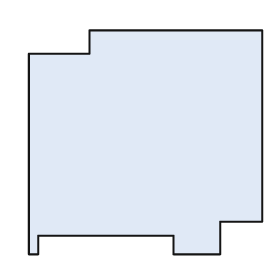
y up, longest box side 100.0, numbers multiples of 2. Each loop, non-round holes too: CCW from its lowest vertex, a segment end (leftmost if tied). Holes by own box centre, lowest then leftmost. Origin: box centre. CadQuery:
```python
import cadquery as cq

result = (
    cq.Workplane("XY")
    .moveTo(-50.0, -48.0)
    .lineTo(-46.0, -48.0)
    .lineTo(-46.0, -40.0)
    .lineTo(12.0, -40.0)
    .lineTo(12.0, -48.0)
    .lineTo(32.0, -48.0)
    .lineTo(32.0, -34.0)
    .lineTo(50.0, -34.0)
    .lineTo(50.0, 48.0)
    .lineTo(-24.0, 48.0)
    .lineTo(-24.0, 38.0)
    .lineTo(-50.0, 38.0)
    .close()
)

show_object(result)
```